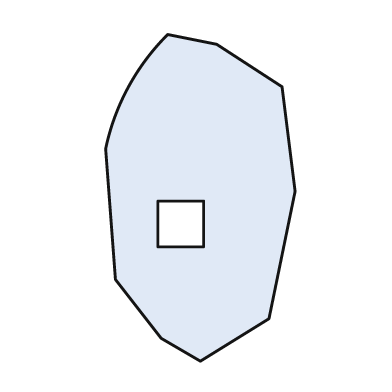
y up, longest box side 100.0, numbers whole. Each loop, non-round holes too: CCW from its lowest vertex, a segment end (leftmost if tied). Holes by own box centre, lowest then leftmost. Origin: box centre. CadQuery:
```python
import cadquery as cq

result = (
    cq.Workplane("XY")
    .moveTo(0.0, -50.0)
    .lineTo(21.0, -37.0)
    .lineTo(29.0, 2.0)
    .lineTo(25.0, 34.0)
    .lineTo(5.0, 47.0)
    .lineTo(-10.0, 50.0)
    .threePointArc((-22.0, 34.0), (-29.0, 15.0))
    .lineTo(-26.0, -25.0)
    .lineTo(-12.0, -43.0)
    .close()
    .moveTo(-13.0, -15.0)
    .lineTo(1.0, -15.0)
    .lineTo(1.0, -1.0)
    .lineTo(-13.0, -1.0)
    .close()
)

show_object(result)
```